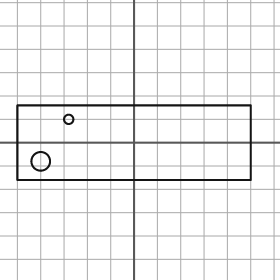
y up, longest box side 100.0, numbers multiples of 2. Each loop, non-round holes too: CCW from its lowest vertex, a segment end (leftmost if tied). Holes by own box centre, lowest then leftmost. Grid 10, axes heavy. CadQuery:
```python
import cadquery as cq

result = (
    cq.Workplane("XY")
    .moveTo(-50.0, -16.0)
    .lineTo(50.0, -16.0)
    .lineTo(50.0, 16.0)
    .lineTo(-50.0, 16.0)
    .close()
    .moveTo(-40.0, -8.0)
    .circle(4.0)
    .moveTo(-28.0, 10.0)
    .circle(2.0)
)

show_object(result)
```